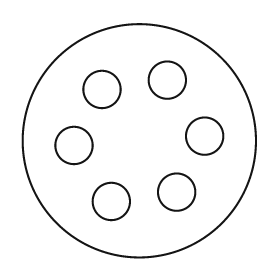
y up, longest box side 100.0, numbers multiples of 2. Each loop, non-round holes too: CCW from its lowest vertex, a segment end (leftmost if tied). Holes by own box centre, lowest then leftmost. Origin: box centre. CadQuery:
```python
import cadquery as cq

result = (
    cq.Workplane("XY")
    .moveTo(0.0, 0.0)
    .circle(50.0)
    .moveTo(-12.0, -26.0)
    .circle(8.0)
    .moveTo(16.0, -22.0)
    .circle(8.0)
    .moveTo(-28.0, -2.0)
    .circle(8.0)
    .moveTo(28.0, 2.0)
    .circle(8.0)
    .moveTo(-16.0, 22.0)
    .circle(8.0)
    .moveTo(12.0, 26.0)
    .circle(8.0)
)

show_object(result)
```